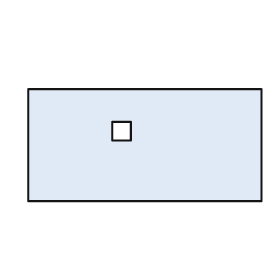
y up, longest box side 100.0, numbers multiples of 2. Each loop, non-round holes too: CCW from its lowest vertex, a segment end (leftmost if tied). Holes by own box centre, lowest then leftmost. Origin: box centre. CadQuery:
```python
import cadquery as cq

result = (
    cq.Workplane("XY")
    .moveTo(-50.0, -24.0)
    .lineTo(50.0, -24.0)
    .lineTo(50.0, 24.0)
    .lineTo(-50.0, 24.0)
    .close()
    .moveTo(-14.0, 2.0)
    .lineTo(-6.0, 2.0)
    .lineTo(-6.0, 10.0)
    .lineTo(-14.0, 10.0)
    .close()
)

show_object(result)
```